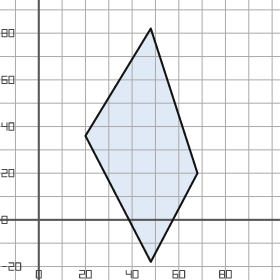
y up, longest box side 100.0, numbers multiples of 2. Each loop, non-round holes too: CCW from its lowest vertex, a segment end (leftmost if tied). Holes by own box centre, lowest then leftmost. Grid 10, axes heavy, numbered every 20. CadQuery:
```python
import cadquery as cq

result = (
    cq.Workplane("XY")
    .moveTo(48.0, -18.0)
    .lineTo(68.0, 20.0)
    .lineTo(48.0, 82.0)
    .lineTo(20.0, 36.0)
    .close()
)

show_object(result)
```